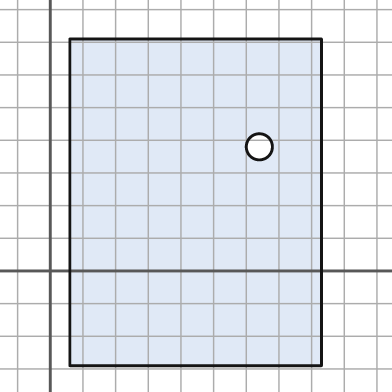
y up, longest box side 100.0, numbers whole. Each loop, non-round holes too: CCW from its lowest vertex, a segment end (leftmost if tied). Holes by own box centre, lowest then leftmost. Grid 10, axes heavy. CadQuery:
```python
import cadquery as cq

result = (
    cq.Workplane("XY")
    .moveTo(6.0, -29.0)
    .lineTo(83.0, -29.0)
    .lineTo(83.0, 71.0)
    .lineTo(6.0, 71.0)
    .close()
    .moveTo(64.0, 38.0)
    .circle(4.0)
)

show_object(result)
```